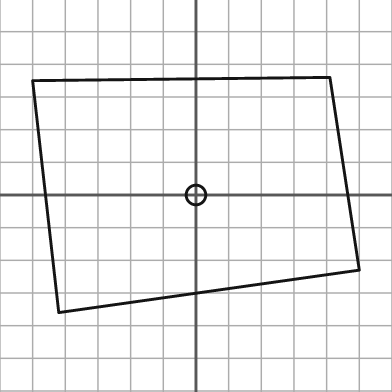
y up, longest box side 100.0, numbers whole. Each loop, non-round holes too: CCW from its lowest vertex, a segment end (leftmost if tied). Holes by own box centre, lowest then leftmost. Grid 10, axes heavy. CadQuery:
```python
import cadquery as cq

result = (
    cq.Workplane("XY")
    .moveTo(-42.0, -36.0)
    .lineTo(50.0, -23.0)
    .lineTo(41.0, 36.0)
    .lineTo(-50.0, 35.0)
    .close()
    .moveTo(0.0, 0.0)
    .circle(3.0)
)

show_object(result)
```